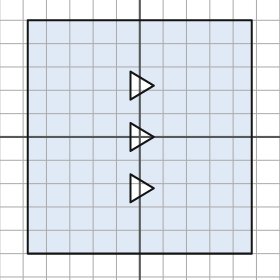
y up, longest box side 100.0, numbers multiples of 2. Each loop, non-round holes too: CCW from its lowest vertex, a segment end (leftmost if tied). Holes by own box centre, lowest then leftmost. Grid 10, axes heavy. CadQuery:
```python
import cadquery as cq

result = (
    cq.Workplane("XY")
    .moveTo(-48.0, -50.0)
    .lineTo(48.0, -50.0)
    .lineTo(48.0, 50.0)
    .lineTo(-48.0, 50.0)
    .close()
    .moveTo(-4.0, -28.0)
    .lineTo(6.0, -22.0)
    .lineTo(-4.0, -16.0)
    .close()
    .moveTo(-4.0, -6.0)
    .lineTo(6.0, 0.0)
    .lineTo(-4.0, 6.0)
    .close()
    .moveTo(-4.0, 16.0)
    .lineTo(6.0, 22.0)
    .lineTo(-4.0, 28.0)
    .close()
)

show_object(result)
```